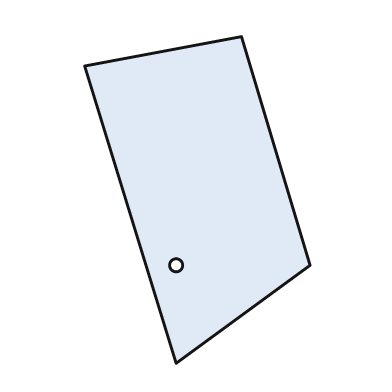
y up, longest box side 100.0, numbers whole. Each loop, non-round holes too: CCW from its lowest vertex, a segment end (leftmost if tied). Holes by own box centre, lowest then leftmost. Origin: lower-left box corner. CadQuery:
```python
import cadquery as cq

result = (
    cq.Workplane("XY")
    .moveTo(28.0, 0.0)
    .lineTo(69.0, 30.0)
    .lineTo(48.0, 100.0)
    .lineTo(0.0, 91.0)
    .close()
    .moveTo(28.0, 30.0)
    .circle(2.0)
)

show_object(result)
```